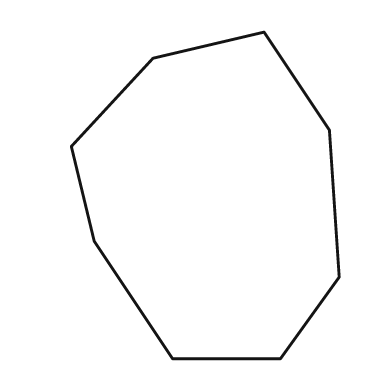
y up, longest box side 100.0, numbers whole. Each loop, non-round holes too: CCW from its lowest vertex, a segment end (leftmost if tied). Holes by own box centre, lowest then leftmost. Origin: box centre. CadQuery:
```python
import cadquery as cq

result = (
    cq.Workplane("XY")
    .moveTo(-10.0, -50.0)
    .lineTo(23.0, -50.0)
    .lineTo(41.0, -25.0)
    .lineTo(38.0, 20.0)
    .lineTo(18.0, 50.0)
    .lineTo(-16.0, 42.0)
    .lineTo(-41.0, 15.0)
    .lineTo(-34.0, -14.0)
    .close()
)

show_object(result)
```